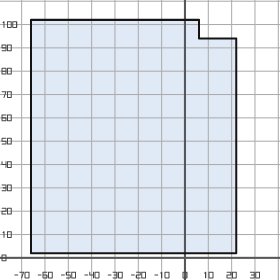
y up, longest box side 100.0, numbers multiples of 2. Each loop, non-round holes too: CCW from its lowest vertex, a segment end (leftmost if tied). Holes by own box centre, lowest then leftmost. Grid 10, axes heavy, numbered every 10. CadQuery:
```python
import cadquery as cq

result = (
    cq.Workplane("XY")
    .moveTo(-66.0, 2.0)
    .lineTo(22.0, 2.0)
    .lineTo(22.0, 94.0)
    .lineTo(6.0, 94.0)
    .lineTo(6.0, 102.0)
    .lineTo(-66.0, 102.0)
    .close()
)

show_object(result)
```